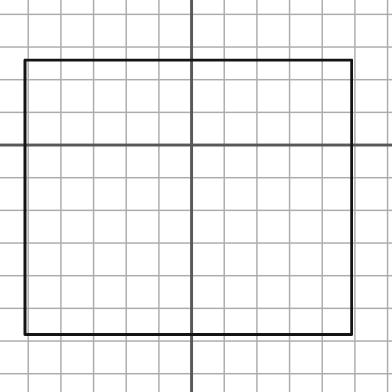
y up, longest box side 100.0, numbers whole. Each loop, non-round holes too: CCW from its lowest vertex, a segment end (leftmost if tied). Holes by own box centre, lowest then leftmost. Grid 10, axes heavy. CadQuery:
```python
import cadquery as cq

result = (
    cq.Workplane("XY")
    .moveTo(-51.0, -58.0)
    .lineTo(49.0, -58.0)
    .lineTo(49.0, 26.0)
    .lineTo(-51.0, 26.0)
    .close()
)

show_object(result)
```